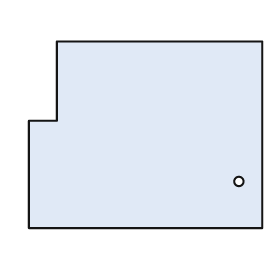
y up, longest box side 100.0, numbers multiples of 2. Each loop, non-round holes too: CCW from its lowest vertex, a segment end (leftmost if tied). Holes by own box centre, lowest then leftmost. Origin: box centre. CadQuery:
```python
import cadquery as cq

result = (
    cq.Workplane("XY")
    .moveTo(-50.0, -40.0)
    .lineTo(50.0, -40.0)
    .lineTo(50.0, 40.0)
    .lineTo(-38.0, 40.0)
    .lineTo(-38.0, 6.0)
    .lineTo(-50.0, 6.0)
    .close()
    .moveTo(40.0, -20.0)
    .circle(2.0)
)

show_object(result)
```